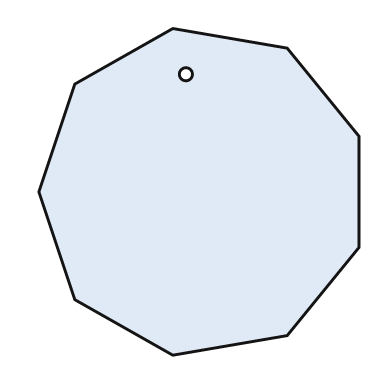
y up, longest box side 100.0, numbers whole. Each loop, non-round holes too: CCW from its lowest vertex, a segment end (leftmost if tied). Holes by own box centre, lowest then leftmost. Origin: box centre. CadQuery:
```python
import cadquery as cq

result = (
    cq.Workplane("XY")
    .moveTo(-8.0, -50.0)
    .lineTo(27.0, -44.0)
    .lineTo(49.0, -17.0)
    .lineTo(49.0, 17.0)
    .lineTo(27.0, 44.0)
    .lineTo(-8.0, 50.0)
    .lineTo(-38.0, 33.0)
    .lineTo(-49.0, 0.0)
    .lineTo(-38.0, -33.0)
    .close()
    .moveTo(-4.0, 36.0)
    .circle(2.0)
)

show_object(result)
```